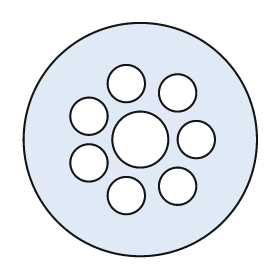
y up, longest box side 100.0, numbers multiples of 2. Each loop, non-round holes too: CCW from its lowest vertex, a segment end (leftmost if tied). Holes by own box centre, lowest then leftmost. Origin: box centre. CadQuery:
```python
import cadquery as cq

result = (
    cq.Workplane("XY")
    .moveTo(0.0, 0.0)
    .circle(50.0)
    .moveTo(-6.0, -24.0)
    .circle(8.0)
    .moveTo(16.0, -20.0)
    .circle(8.0)
    .moveTo(-22.0, -10.0)
    .circle(8.0)
    .moveTo(0.0, 0.0)
    .circle(12.0)
    .moveTo(24.0, 0.0)
    .circle(8.0)
    .moveTo(-22.0, 10.0)
    .circle(8.0)
    .moveTo(16.0, 20.0)
    .circle(8.0)
    .moveTo(-6.0, 24.0)
    .circle(8.0)
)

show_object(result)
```